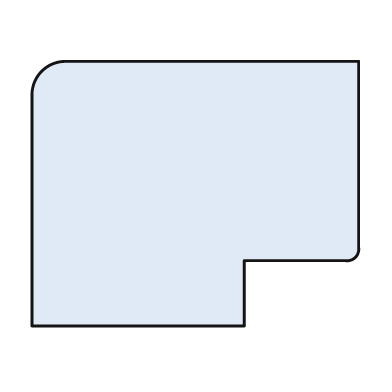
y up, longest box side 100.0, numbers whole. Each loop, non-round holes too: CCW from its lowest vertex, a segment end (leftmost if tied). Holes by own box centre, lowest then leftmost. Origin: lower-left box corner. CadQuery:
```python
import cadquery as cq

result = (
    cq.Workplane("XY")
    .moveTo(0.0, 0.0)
    .lineTo(65.0, 0.0)
    .lineTo(65.0, 20.0)
    .lineTo(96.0, 20.0)
    .threePointArc((99.0, 21.0), (100.0, 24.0))
    .lineTo(100.0, 81.0)
    .lineTo(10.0, 81.0)
    .threePointArc((3.0, 78.0), (0.0, 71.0))
    .close()
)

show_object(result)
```